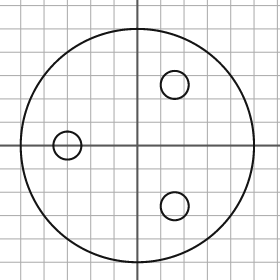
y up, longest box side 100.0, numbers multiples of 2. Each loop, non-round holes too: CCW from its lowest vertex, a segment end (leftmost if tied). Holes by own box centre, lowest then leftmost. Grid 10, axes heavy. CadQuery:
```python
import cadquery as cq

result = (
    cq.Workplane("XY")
    .moveTo(0.0, 0.0)
    .circle(50.0)
    .moveTo(16.0, -26.0)
    .circle(6.0)
    .moveTo(-30.0, 0.0)
    .circle(6.0)
    .moveTo(16.0, 26.0)
    .circle(6.0)
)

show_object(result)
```